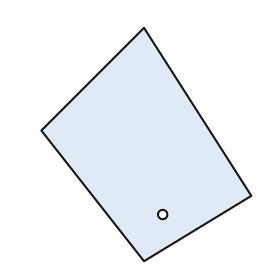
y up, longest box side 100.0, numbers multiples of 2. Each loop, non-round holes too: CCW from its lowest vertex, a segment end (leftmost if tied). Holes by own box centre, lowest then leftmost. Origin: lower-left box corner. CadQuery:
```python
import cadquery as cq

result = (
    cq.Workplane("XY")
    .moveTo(44.0, 0.0)
    .lineTo(90.0, 28.0)
    .lineTo(44.0, 100.0)
    .lineTo(0.0, 56.0)
    .close()
    .moveTo(52.0, 20.0)
    .circle(2.0)
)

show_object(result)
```